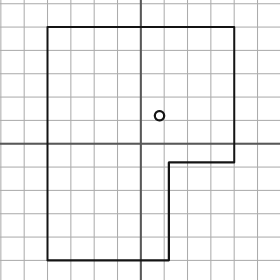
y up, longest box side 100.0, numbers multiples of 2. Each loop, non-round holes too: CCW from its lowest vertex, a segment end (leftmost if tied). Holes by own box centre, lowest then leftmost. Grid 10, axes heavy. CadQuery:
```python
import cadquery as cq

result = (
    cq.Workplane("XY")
    .moveTo(-40.0, -50.0)
    .lineTo(12.0, -50.0)
    .lineTo(12.0, -8.0)
    .lineTo(40.0, -8.0)
    .lineTo(40.0, 50.0)
    .lineTo(-40.0, 50.0)
    .close()
    .moveTo(8.0, 12.0)
    .circle(2.0)
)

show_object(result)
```